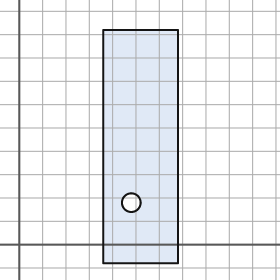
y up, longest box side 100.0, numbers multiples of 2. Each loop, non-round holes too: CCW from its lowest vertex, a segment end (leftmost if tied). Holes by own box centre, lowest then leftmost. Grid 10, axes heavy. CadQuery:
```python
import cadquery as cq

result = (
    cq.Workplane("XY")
    .moveTo(36.0, -8.0)
    .lineTo(68.0, -8.0)
    .lineTo(68.0, 92.0)
    .lineTo(36.0, 92.0)
    .close()
    .moveTo(48.0, 18.0)
    .circle(4.0)
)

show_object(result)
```